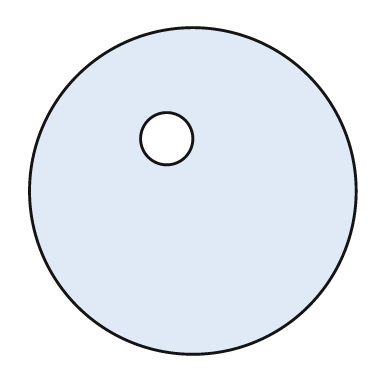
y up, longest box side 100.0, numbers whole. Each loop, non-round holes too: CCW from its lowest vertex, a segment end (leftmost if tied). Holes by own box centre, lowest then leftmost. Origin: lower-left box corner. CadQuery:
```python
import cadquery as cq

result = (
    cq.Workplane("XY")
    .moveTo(50.0, 50.0)
    .circle(50.0)
    .moveTo(42.0, 66.0)
    .circle(8.0)
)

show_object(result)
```